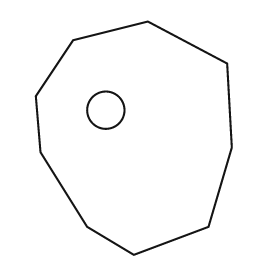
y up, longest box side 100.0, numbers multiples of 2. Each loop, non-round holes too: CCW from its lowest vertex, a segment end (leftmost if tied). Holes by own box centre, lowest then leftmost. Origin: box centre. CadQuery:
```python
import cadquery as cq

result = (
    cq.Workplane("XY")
    .moveTo(0.0, -50.0)
    .lineTo(32.0, -38.0)
    .lineTo(42.0, -4.0)
    .lineTo(40.0, 32.0)
    .lineTo(6.0, 50.0)
    .lineTo(-26.0, 42.0)
    .lineTo(-42.0, 18.0)
    .lineTo(-40.0, -6.0)
    .lineTo(-20.0, -38.0)
    .close()
    .moveTo(-12.0, 12.0)
    .circle(8.0)
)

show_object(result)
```